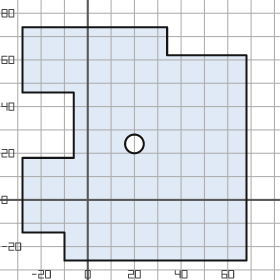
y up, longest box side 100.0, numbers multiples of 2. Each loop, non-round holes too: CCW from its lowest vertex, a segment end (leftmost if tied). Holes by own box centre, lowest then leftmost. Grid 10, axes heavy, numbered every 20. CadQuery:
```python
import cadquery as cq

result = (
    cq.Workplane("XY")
    .moveTo(-10.0, -26.0)
    .lineTo(68.0, -26.0)
    .lineTo(68.0, 62.0)
    .lineTo(34.0, 62.0)
    .lineTo(34.0, 74.0)
    .lineTo(-28.0, 74.0)
    .lineTo(-28.0, 46.0)
    .lineTo(-6.0, 46.0)
    .lineTo(-6.0, 18.0)
    .lineTo(-28.0, 18.0)
    .lineTo(-28.0, -14.0)
    .lineTo(-10.0, -14.0)
    .close()
    .moveTo(20.0, 24.0)
    .circle(4.0)
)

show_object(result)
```